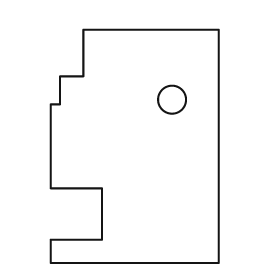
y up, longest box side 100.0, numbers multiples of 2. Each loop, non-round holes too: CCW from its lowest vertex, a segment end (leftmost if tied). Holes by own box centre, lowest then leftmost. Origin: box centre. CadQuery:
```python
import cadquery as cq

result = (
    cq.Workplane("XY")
    .moveTo(-36.0, -50.0)
    .lineTo(36.0, -50.0)
    .lineTo(36.0, 50.0)
    .lineTo(-22.0, 50.0)
    .lineTo(-22.0, 30.0)
    .lineTo(-32.0, 30.0)
    .lineTo(-32.0, 18.0)
    .lineTo(-36.0, 18.0)
    .lineTo(-36.0, -18.0)
    .lineTo(-14.0, -18.0)
    .lineTo(-14.0, -40.0)
    .lineTo(-36.0, -40.0)
    .close()
    .moveTo(16.0, 20.0)
    .circle(6.0)
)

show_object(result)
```